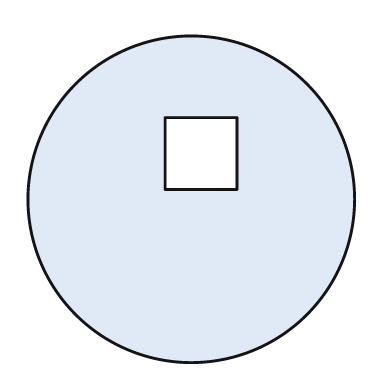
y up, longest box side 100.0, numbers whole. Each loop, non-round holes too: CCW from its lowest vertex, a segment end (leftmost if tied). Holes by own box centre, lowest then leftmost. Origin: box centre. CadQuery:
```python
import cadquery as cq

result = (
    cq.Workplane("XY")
    .moveTo(0.0, 0.0)
    .circle(50.0)
    .moveTo(-8.0, 3.0)
    .lineTo(14.0, 3.0)
    .lineTo(14.0, 25.0)
    .lineTo(-8.0, 25.0)
    .close()
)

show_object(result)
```